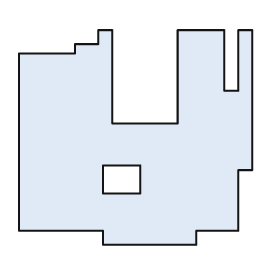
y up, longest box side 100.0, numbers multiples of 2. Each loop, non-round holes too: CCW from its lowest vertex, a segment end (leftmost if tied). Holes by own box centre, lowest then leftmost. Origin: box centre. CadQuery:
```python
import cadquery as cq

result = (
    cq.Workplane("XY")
    .moveTo(-14.0, -46.0)
    .lineTo(26.0, -46.0)
    .lineTo(26.0, -40.0)
    .lineTo(44.0, -40.0)
    .lineTo(44.0, -14.0)
    .lineTo(50.0, -14.0)
    .lineTo(50.0, 46.0)
    .lineTo(44.0, 46.0)
    .lineTo(44.0, 20.0)
    .lineTo(38.0, 20.0)
    .lineTo(38.0, 46.0)
    .lineTo(18.0, 46.0)
    .lineTo(18.0, 6.0)
    .lineTo(-10.0, 6.0)
    .lineTo(-10.0, 46.0)
    .lineTo(-16.0, 46.0)
    .lineTo(-16.0, 40.0)
    .lineTo(-26.0, 40.0)
    .lineTo(-26.0, 36.0)
    .lineTo(-50.0, 36.0)
    .lineTo(-50.0, -40.0)
    .lineTo(-14.0, -40.0)
    .close()
    .moveTo(-14.0, -24.0)
    .lineTo(2.0, -24.0)
    .lineTo(2.0, -12.0)
    .lineTo(-14.0, -12.0)
    .close()
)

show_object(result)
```